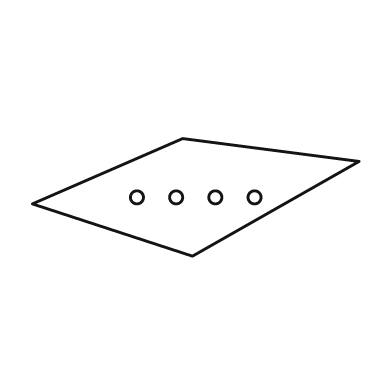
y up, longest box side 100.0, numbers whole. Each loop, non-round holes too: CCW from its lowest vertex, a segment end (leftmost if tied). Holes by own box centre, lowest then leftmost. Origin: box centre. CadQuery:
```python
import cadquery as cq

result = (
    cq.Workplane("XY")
    .moveTo(-1.0, -18.0)
    .lineTo(50.0, 11.0)
    .lineTo(-4.0, 18.0)
    .lineTo(-50.0, -2.0)
    .close()
    .moveTo(-18.0, 0.0)
    .circle(2.0)
    .moveTo(-6.0, 0.0)
    .circle(2.0)
    .moveTo(6.0, 0.0)
    .circle(2.0)
    .moveTo(18.0, 0.0)
    .circle(2.0)
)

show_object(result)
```